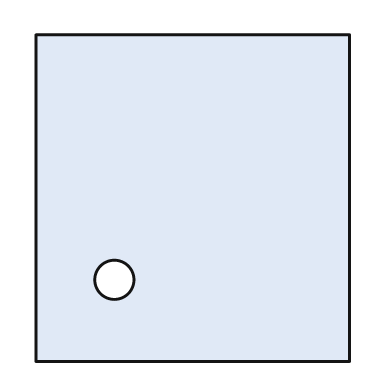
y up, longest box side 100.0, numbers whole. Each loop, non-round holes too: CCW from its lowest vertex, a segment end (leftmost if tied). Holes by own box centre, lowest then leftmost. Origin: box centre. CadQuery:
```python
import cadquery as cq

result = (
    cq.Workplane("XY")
    .moveTo(-48.0, -50.0)
    .lineTo(48.0, -50.0)
    .lineTo(48.0, 50.0)
    .lineTo(-48.0, 50.0)
    .close()
    .moveTo(-24.0, -25.0)
    .circle(6.0)
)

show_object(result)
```